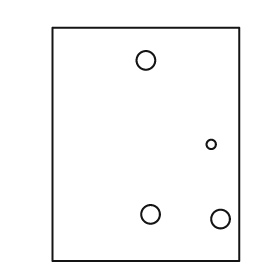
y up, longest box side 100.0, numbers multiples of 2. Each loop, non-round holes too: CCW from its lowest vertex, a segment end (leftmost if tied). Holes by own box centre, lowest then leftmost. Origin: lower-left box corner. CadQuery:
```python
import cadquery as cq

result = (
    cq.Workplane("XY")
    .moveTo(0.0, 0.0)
    .lineTo(80.0, 0.0)
    .lineTo(80.0, 100.0)
    .lineTo(0.0, 100.0)
    .close()
    .moveTo(72.0, 18.0)
    .circle(4.0)
    .moveTo(42.0, 20.0)
    .circle(4.0)
    .moveTo(68.0, 50.0)
    .circle(2.0)
    .moveTo(40.0, 86.0)
    .circle(4.0)
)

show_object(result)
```